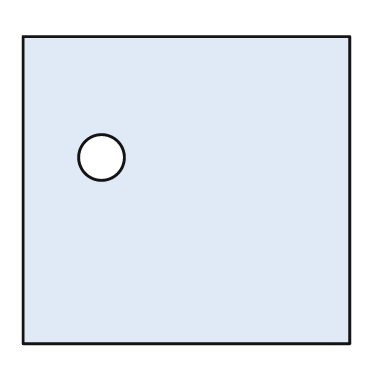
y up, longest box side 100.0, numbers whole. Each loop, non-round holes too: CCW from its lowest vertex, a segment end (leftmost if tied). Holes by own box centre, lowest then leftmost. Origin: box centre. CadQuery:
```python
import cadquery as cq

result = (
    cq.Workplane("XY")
    .moveTo(-50.0, -47.0)
    .lineTo(50.0, -47.0)
    .lineTo(50.0, 47.0)
    .lineTo(-50.0, 47.0)
    .close()
    .moveTo(-26.0, 10.0)
    .circle(7.0)
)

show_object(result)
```